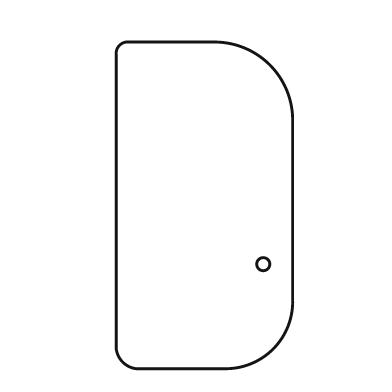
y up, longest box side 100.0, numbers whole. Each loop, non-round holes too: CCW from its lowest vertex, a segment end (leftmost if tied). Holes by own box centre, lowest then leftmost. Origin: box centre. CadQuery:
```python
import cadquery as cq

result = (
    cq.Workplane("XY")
    .moveTo(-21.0, -50.0)
    .lineTo(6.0, -50.0)
    .threePointArc((21.0, -44.0), (27.0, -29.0))
    .lineTo(27.0, 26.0)
    .threePointArc((20.0, 43.0), (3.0, 50.0))
    .lineTo(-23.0, 50.0)
    .threePointArc((-26.0, 49.0), (-27.0, 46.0))
    .lineTo(-27.0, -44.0)
    .threePointArc((-25.0, -48.0), (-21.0, -50.0))
    .close()
    .moveTo(18.0, -18.0)
    .circle(2.0)
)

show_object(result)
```